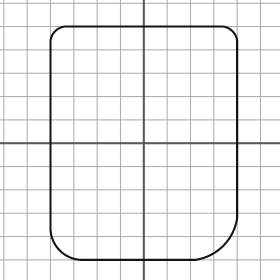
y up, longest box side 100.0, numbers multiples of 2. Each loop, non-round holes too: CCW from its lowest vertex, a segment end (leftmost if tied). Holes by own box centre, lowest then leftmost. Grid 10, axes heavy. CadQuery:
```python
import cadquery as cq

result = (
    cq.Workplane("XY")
    .moveTo(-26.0, -50.0)
    .lineTo(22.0, -50.0)
    .threePointArc((34.0, -44.0), (40.0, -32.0))
    .lineTo(40.0, 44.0)
    .threePointArc((38.0, 48.0), (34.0, 50.0))
    .lineTo(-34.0, 50.0)
    .threePointArc((-38.0, 48.0), (-40.0, 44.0))
    .lineTo(-40.0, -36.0)
    .threePointArc((-36.0, -46.0), (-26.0, -50.0))
    .close()
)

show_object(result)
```